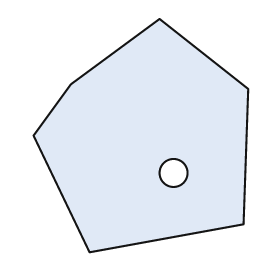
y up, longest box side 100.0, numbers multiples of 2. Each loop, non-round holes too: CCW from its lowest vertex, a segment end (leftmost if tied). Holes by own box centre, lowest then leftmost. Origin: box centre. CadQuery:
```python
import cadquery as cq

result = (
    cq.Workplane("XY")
    .moveTo(-22.0, -50.0)
    .lineTo(44.0, -38.0)
    .lineTo(46.0, 20.0)
    .lineTo(8.0, 50.0)
    .lineTo(-30.0, 22.0)
    .lineTo(-46.0, 0.0)
    .close()
    .moveTo(14.0, -16.0)
    .circle(6.0)
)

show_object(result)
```